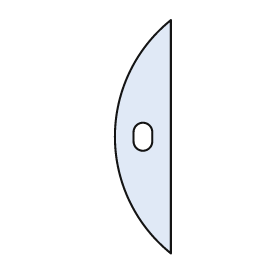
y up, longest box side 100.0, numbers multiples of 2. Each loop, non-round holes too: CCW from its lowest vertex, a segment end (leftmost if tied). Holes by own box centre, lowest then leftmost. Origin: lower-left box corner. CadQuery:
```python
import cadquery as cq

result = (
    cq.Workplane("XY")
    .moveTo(24.0, 0.0)
    .lineTo(24.0, 100.0)
    .threePointArc((0.0, 50.0), (24.0, 0.0))
    .close()
    .moveTo(8.0, 48.0)
    .threePointArc((12.0, 44.0), (16.0, 48.0))
    .lineTo(16.0, 52.0)
    .threePointArc((12.0, 56.0), (8.0, 52.0))
    .close()
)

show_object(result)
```